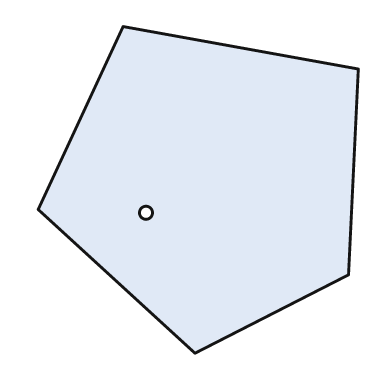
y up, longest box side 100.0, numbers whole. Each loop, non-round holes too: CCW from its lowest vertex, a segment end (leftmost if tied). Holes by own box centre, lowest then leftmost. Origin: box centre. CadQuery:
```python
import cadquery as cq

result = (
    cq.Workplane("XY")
    .moveTo(-1.0, -50.0)
    .lineTo(46.0, -26.0)
    .lineTo(49.0, 37.0)
    .lineTo(-23.0, 50.0)
    .lineTo(-49.0, -6.0)
    .close()
    .moveTo(-16.0, -7.0)
    .circle(2.0)
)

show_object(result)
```